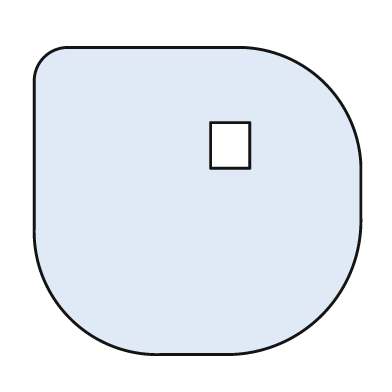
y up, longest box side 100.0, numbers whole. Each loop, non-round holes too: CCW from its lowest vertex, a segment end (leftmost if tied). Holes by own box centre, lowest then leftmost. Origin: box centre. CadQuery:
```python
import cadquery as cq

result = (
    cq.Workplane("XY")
    .moveTo(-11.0, -47.0)
    .lineTo(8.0, -47.0)
    .threePointArc((38.0, -35.0), (50.0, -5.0))
    .lineTo(50.0, 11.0)
    .threePointArc((39.0, 36.0), (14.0, 47.0))
    .lineTo(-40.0, 47.0)
    .threePointArc((-47.0, 44.0), (-50.0, 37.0))
    .lineTo(-50.0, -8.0)
    .threePointArc((-39.0, -36.0), (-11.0, -47.0))
    .close()
    .moveTo(4.0, 10.0)
    .lineTo(16.0, 10.0)
    .lineTo(16.0, 24.0)
    .lineTo(4.0, 24.0)
    .close()
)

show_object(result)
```